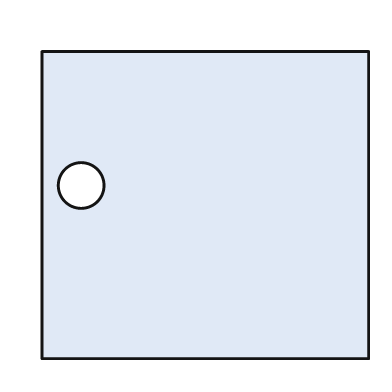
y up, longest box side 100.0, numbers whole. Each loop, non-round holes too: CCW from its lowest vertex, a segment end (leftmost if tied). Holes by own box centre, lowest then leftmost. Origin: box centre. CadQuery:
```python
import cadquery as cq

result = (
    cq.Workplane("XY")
    .moveTo(-50.0, -47.0)
    .lineTo(50.0, -47.0)
    .lineTo(50.0, 47.0)
    .lineTo(-50.0, 47.0)
    .close()
    .moveTo(-38.0, 6.0)
    .circle(7.0)
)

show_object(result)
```